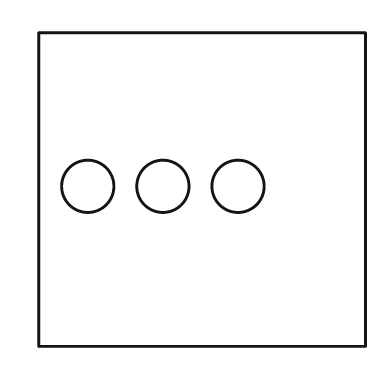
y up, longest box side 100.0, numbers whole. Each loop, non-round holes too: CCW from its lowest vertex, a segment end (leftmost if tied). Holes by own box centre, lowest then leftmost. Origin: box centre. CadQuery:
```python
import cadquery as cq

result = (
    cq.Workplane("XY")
    .moveTo(-50.0, -48.0)
    .lineTo(50.0, -48.0)
    .lineTo(50.0, 48.0)
    .lineTo(-50.0, 48.0)
    .close()
    .moveTo(-35.0, 1.0)
    .circle(8.0)
    .moveTo(-12.0, 1.0)
    .circle(8.0)
    .moveTo(11.0, 1.0)
    .circle(8.0)
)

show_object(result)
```